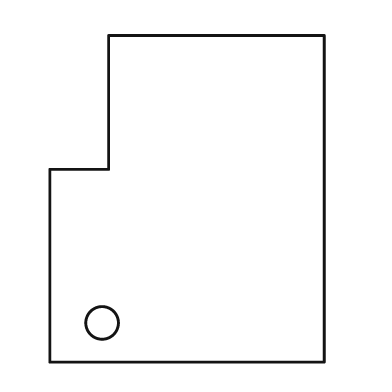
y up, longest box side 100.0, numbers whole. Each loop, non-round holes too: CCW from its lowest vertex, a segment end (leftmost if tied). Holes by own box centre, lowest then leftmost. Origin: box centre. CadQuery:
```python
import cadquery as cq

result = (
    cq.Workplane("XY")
    .moveTo(-42.0, -50.0)
    .lineTo(42.0, -50.0)
    .lineTo(42.0, 50.0)
    .lineTo(-24.0, 50.0)
    .lineTo(-24.0, 9.0)
    .lineTo(-42.0, 9.0)
    .close()
    .moveTo(-26.0, -38.0)
    .circle(5.0)
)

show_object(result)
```